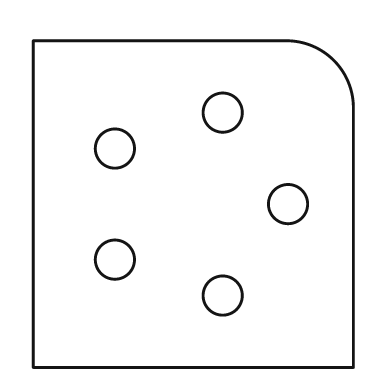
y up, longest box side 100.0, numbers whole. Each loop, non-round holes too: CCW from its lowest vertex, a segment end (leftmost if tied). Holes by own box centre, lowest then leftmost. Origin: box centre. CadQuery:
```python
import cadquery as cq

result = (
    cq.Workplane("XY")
    .moveTo(-49.0, -50.0)
    .lineTo(49.0, -50.0)
    .lineTo(49.0, 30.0)
    .threePointArc((43.0, 44.0), (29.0, 50.0))
    .lineTo(-49.0, 50.0)
    .close()
    .moveTo(9.0, -28.0)
    .circle(6.0)
    .moveTo(-24.0, -17.0)
    .circle(6.0)
    .moveTo(29.0, 0.0)
    .circle(6.0)
    .moveTo(-24.0, 17.0)
    .circle(6.0)
    .moveTo(9.0, 28.0)
    .circle(6.0)
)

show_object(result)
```